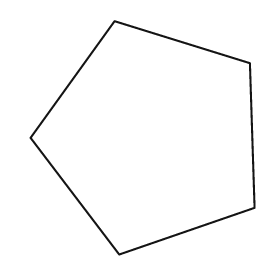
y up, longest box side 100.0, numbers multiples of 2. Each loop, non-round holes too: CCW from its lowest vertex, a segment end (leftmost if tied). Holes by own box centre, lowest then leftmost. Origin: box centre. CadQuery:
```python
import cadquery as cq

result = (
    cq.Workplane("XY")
    .moveTo(-10.0, -50.0)
    .lineTo(48.0, -30.0)
    .lineTo(46.0, 32.0)
    .lineTo(-12.0, 50.0)
    .lineTo(-48.0, 0.0)
    .close()
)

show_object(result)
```